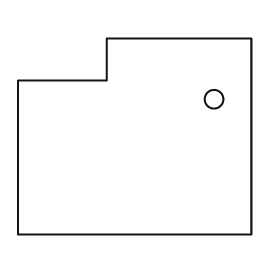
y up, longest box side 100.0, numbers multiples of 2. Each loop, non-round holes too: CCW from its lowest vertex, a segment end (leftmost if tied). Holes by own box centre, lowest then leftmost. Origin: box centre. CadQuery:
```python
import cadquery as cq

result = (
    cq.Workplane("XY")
    .moveTo(-50.0, -42.0)
    .lineTo(50.0, -42.0)
    .lineTo(50.0, 42.0)
    .lineTo(-12.0, 42.0)
    .lineTo(-12.0, 24.0)
    .lineTo(-50.0, 24.0)
    .close()
    .moveTo(34.0, 16.0)
    .circle(4.0)
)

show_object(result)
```